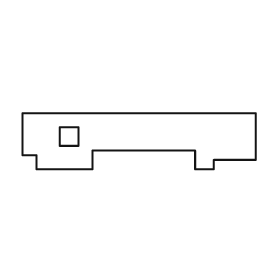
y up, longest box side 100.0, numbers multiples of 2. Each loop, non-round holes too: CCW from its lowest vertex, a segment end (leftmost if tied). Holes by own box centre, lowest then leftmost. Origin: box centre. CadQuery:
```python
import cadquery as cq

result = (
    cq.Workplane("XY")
    .moveTo(-44.0, -12.0)
    .lineTo(-20.0, -12.0)
    .lineTo(-20.0, -4.0)
    .lineTo(24.0, -4.0)
    .lineTo(24.0, -12.0)
    .lineTo(32.0, -12.0)
    .lineTo(32.0, -8.0)
    .lineTo(50.0, -8.0)
    .lineTo(50.0, 12.0)
    .lineTo(-50.0, 12.0)
    .lineTo(-50.0, -6.0)
    .lineTo(-44.0, -6.0)
    .close()
    .moveTo(-34.0, -2.0)
    .lineTo(-26.0, -2.0)
    .lineTo(-26.0, 6.0)
    .lineTo(-34.0, 6.0)
    .close()
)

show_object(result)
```